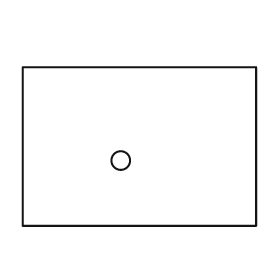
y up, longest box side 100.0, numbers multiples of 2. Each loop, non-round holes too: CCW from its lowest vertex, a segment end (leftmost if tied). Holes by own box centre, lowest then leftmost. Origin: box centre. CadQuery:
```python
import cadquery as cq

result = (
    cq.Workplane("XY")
    .moveTo(-50.0, -34.0)
    .lineTo(50.0, -34.0)
    .lineTo(50.0, 34.0)
    .lineTo(-50.0, 34.0)
    .close()
    .moveTo(-8.0, -6.0)
    .circle(4.0)
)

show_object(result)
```